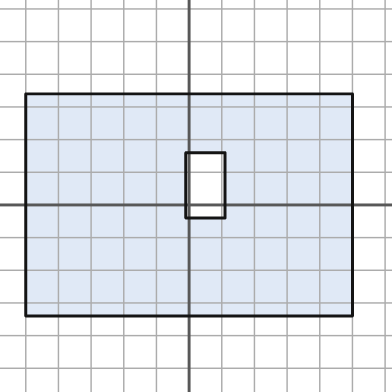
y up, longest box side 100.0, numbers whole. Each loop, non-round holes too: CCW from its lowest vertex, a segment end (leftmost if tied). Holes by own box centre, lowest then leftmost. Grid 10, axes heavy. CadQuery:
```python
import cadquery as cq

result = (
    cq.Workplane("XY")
    .moveTo(-50.0, -34.0)
    .lineTo(50.0, -34.0)
    .lineTo(50.0, 34.0)
    .lineTo(-50.0, 34.0)
    .close()
    .moveTo(-1.0, -4.0)
    .lineTo(11.0, -4.0)
    .lineTo(11.0, 16.0)
    .lineTo(-1.0, 16.0)
    .close()
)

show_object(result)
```